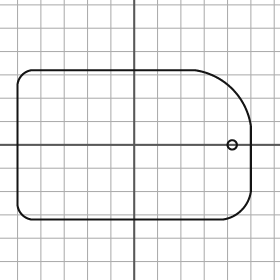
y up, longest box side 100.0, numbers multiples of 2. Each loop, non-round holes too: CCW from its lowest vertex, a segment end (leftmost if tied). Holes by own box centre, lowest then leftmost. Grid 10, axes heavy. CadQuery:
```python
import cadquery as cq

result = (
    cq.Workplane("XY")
    .moveTo(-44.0, -32.0)
    .lineTo(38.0, -32.0)
    .threePointArc((46.0, -28.0), (50.0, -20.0))
    .lineTo(50.0, 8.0)
    .threePointArc((42.0, 24.0), (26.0, 32.0))
    .lineTo(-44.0, 32.0)
    .threePointArc((-48.0, 30.0), (-50.0, 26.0))
    .lineTo(-50.0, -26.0)
    .threePointArc((-48.0, -30.0), (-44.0, -32.0))
    .close()
    .moveTo(42.0, 0.0)
    .circle(2.0)
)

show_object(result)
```